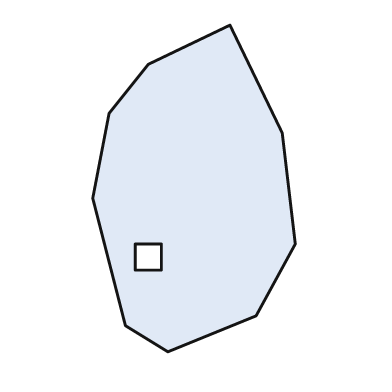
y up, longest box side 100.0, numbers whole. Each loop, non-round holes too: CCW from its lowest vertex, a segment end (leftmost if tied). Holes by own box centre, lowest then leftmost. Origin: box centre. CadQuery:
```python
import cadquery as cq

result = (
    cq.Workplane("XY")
    .moveTo(-8.0, -50.0)
    .lineTo(19.0, -39.0)
    .lineTo(31.0, -17.0)
    .lineTo(27.0, 17.0)
    .lineTo(11.0, 50.0)
    .lineTo(-14.0, 38.0)
    .lineTo(-26.0, 23.0)
    .lineTo(-31.0, -3.0)
    .lineTo(-21.0, -42.0)
    .close()
    .moveTo(-18.0, -25.0)
    .lineTo(-10.0, -25.0)
    .lineTo(-10.0, -17.0)
    .lineTo(-18.0, -17.0)
    .close()
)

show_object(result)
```